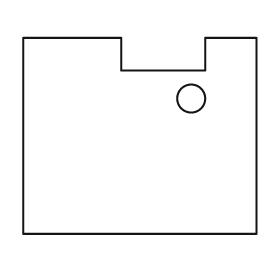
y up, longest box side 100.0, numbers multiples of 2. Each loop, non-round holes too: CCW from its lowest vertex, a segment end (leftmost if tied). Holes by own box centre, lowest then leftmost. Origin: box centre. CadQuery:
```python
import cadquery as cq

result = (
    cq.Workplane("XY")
    .moveTo(-50.0, -42.0)
    .lineTo(50.0, -42.0)
    .lineTo(50.0, 42.0)
    .lineTo(28.0, 42.0)
    .lineTo(28.0, 28.0)
    .lineTo(-8.0, 28.0)
    .lineTo(-8.0, 42.0)
    .lineTo(-50.0, 42.0)
    .close()
    .moveTo(22.0, 16.0)
    .circle(6.0)
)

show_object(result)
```